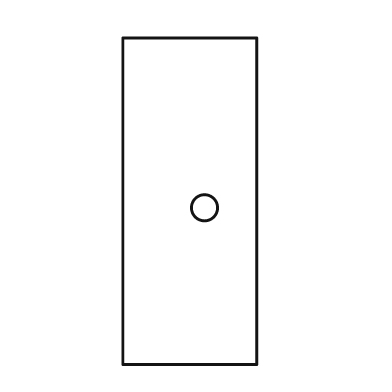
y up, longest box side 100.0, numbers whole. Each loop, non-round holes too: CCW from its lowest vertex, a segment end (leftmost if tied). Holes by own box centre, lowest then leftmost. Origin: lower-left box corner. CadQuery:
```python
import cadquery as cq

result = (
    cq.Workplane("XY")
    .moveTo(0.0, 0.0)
    .lineTo(41.0, 0.0)
    .lineTo(41.0, 100.0)
    .lineTo(0.0, 100.0)
    .close()
    .moveTo(25.0, 48.0)
    .circle(4.0)
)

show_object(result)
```